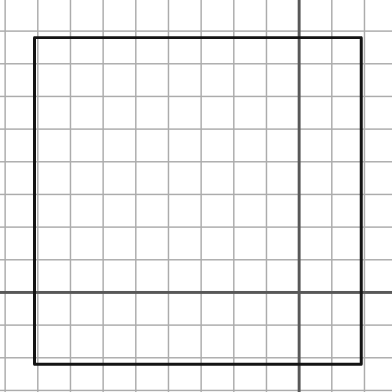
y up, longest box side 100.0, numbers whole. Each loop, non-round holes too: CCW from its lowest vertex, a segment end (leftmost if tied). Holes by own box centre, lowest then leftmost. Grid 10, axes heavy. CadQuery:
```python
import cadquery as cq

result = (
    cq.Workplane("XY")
    .moveTo(-81.0, -22.0)
    .lineTo(19.0, -22.0)
    .lineTo(19.0, 78.0)
    .lineTo(-81.0, 78.0)
    .close()
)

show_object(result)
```